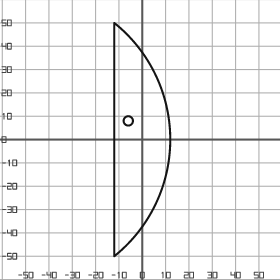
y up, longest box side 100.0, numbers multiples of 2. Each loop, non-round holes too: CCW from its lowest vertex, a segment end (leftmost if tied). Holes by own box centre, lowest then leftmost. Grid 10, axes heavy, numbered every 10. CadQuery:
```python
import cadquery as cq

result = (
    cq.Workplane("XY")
    .moveTo(-12.0, -50.0)
    .threePointArc((12.0, 0.0), (-12.0, 50.0))
    .close()
    .moveTo(-6.0, 8.0)
    .circle(2.0)
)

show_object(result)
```